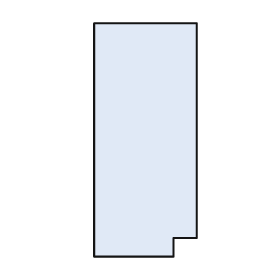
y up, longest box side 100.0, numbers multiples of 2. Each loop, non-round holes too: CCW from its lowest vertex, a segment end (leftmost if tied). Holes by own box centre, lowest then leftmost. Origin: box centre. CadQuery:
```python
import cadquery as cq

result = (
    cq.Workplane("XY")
    .moveTo(-22.0, -50.0)
    .lineTo(12.0, -50.0)
    .lineTo(12.0, -42.0)
    .lineTo(22.0, -42.0)
    .lineTo(22.0, 50.0)
    .lineTo(-22.0, 50.0)
    .close()
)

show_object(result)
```